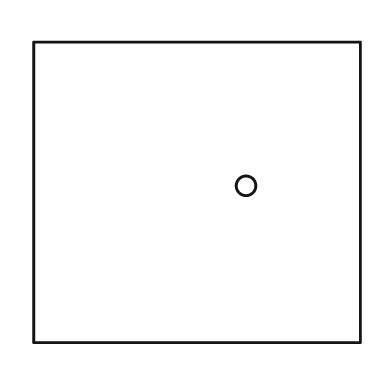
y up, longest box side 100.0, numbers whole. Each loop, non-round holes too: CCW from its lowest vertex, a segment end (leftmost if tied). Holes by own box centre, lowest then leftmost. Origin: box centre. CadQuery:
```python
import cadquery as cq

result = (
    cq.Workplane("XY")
    .moveTo(-50.0, -46.0)
    .lineTo(50.0, -46.0)
    .lineTo(50.0, 46.0)
    .lineTo(-50.0, 46.0)
    .close()
    .moveTo(15.0, 2.0)
    .circle(3.0)
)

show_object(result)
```